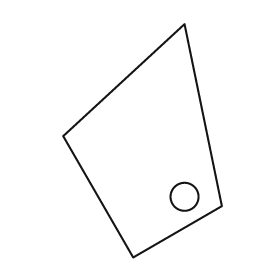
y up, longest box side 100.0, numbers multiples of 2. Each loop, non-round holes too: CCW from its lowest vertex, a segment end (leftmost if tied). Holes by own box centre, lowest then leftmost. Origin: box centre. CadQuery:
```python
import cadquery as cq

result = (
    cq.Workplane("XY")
    .moveTo(-4.0, -50.0)
    .lineTo(34.0, -28.0)
    .lineTo(18.0, 50.0)
    .lineTo(-34.0, 2.0)
    .close()
    .moveTo(18.0, -24.0)
    .circle(6.0)
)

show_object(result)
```